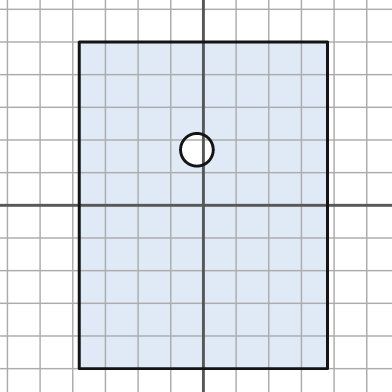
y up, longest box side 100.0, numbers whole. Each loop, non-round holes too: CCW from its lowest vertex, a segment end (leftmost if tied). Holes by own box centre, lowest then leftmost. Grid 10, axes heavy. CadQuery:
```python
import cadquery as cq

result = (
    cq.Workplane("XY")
    .moveTo(-38.0, -50.0)
    .lineTo(38.0, -50.0)
    .lineTo(38.0, 50.0)
    .lineTo(-38.0, 50.0)
    .close()
    .moveTo(-2.0, 17.0)
    .circle(5.0)
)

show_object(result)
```